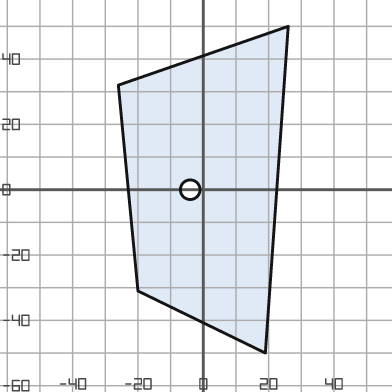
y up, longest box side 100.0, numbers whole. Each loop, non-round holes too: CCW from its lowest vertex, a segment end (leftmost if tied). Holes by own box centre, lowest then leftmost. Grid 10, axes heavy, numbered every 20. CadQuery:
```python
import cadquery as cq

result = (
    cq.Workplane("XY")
    .moveTo(19.0, -50.0)
    .lineTo(26.0, 50.0)
    .lineTo(-26.0, 32.0)
    .lineTo(-20.0, -31.0)
    .close()
    .moveTo(-4.0, 0.0)
    .circle(3.0)
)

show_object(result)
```